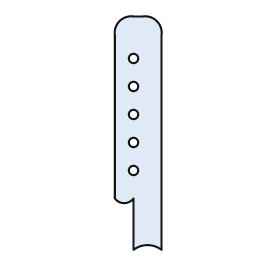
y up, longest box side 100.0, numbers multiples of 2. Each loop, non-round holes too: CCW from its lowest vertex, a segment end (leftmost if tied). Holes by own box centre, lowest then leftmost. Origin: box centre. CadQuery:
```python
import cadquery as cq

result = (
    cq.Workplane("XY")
    .moveTo(-2.0, -50.0)
    .threePointArc((4.0, -48.0), (10.0, -50.0))
    .lineTo(10.0, 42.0)
    .threePointArc((8.0, 48.0), (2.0, 50.0))
    .lineTo(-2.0, 50.0)
    .threePointArc((-8.0, 48.0), (-10.0, 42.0))
    .lineTo(-10.0, -28.0)
    .threePointArc((-6.0, -30.0), (-2.0, -28.0))
    .close()
    .moveTo(-2.0, -16.0)
    .circle(2.0)
    .moveTo(-2.0, -4.0)
    .circle(2.0)
    .moveTo(-2.0, 8.0)
    .circle(2.0)
    .moveTo(-2.0, 20.0)
    .circle(2.0)
    .moveTo(-2.0, 32.0)
    .circle(2.0)
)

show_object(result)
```